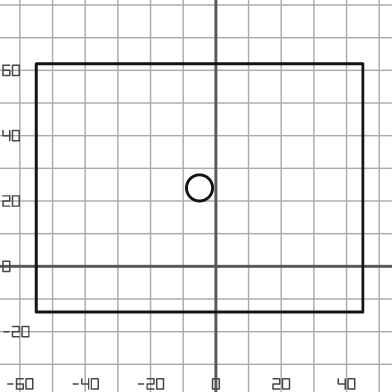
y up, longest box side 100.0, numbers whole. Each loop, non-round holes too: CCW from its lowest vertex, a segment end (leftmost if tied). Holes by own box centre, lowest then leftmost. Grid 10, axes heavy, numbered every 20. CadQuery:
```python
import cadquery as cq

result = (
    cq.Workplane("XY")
    .moveTo(-55.0, -14.0)
    .lineTo(45.0, -14.0)
    .lineTo(45.0, 62.0)
    .lineTo(-55.0, 62.0)
    .close()
    .moveTo(-5.0, 24.0)
    .circle(4.0)
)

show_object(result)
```